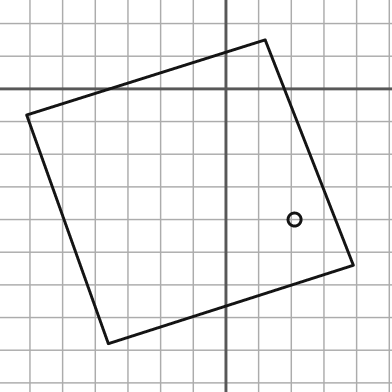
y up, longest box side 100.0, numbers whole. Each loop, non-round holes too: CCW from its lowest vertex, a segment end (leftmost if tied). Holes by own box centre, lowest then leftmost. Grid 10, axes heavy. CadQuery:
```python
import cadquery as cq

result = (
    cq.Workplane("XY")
    .moveTo(-36.0, -78.0)
    .lineTo(39.0, -54.0)
    .lineTo(12.0, 15.0)
    .lineTo(-61.0, -8.0)
    .close()
    .moveTo(21.0, -40.0)
    .circle(2.0)
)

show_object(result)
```